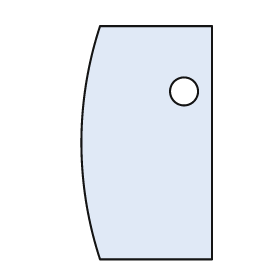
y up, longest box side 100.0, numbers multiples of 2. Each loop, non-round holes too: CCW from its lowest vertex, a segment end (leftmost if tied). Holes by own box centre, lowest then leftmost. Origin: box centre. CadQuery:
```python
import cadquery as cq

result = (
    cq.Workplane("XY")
    .moveTo(-20.0, -50.0)
    .lineTo(28.0, -50.0)
    .lineTo(28.0, 50.0)
    .lineTo(-20.0, 50.0)
    .threePointArc((-28.0, 0.0), (-20.0, -50.0))
    .close()
    .moveTo(16.0, 22.0)
    .circle(6.0)
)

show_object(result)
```